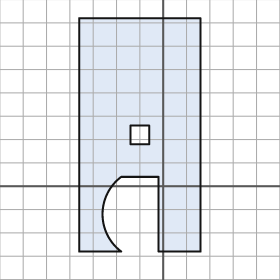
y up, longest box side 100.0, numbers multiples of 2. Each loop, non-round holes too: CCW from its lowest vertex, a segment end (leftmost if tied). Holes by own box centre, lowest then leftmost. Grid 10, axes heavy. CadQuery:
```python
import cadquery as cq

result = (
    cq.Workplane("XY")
    .moveTo(-36.0, -28.0)
    .lineTo(-18.0, -28.0)
    .threePointArc((-26.0, -12.0), (-18.0, 4.0))
    .lineTo(-2.0, 4.0)
    .lineTo(-2.0, -28.0)
    .lineTo(16.0, -28.0)
    .lineTo(16.0, 72.0)
    .lineTo(-36.0, 72.0)
    .close()
    .moveTo(-14.0, 18.0)
    .lineTo(-6.0, 18.0)
    .lineTo(-6.0, 26.0)
    .lineTo(-14.0, 26.0)
    .close()
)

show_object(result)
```